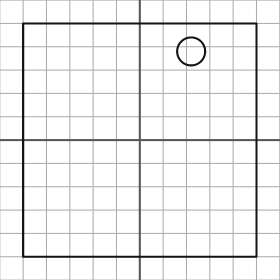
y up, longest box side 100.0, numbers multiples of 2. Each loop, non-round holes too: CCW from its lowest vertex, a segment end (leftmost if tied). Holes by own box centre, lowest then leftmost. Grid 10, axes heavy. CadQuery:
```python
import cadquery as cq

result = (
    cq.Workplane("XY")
    .moveTo(-50.0, -50.0)
    .lineTo(50.0, -50.0)
    .lineTo(50.0, 50.0)
    .lineTo(-50.0, 50.0)
    .close()
    .moveTo(22.0, 38.0)
    .circle(6.0)
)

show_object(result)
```